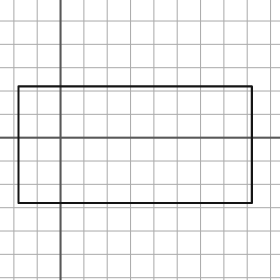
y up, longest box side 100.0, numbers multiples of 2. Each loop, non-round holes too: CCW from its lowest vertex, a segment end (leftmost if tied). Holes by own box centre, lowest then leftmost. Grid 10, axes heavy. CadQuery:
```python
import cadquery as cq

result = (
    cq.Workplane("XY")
    .moveTo(-18.0, -28.0)
    .lineTo(82.0, -28.0)
    .lineTo(82.0, 22.0)
    .lineTo(-18.0, 22.0)
    .close()
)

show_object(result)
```